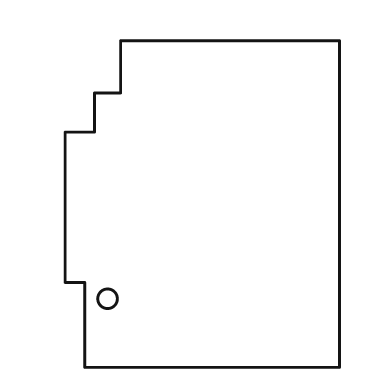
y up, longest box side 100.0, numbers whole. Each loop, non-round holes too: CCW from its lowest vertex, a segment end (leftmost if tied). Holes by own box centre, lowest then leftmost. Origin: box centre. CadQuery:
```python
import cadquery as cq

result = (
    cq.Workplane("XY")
    .moveTo(-36.0, -50.0)
    .lineTo(42.0, -50.0)
    .lineTo(42.0, 50.0)
    .lineTo(-25.0, 50.0)
    .lineTo(-25.0, 34.0)
    .lineTo(-33.0, 34.0)
    .lineTo(-33.0, 22.0)
    .lineTo(-42.0, 22.0)
    .lineTo(-42.0, -24.0)
    .lineTo(-36.0, -24.0)
    .close()
    .moveTo(-29.0, -29.0)
    .circle(3.0)
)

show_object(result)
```